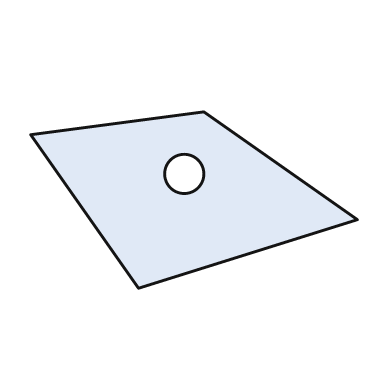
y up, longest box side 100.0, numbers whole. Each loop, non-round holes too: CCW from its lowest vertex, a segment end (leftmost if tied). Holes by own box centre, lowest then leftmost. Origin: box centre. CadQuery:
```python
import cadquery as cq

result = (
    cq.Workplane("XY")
    .moveTo(-17.0, -27.0)
    .lineTo(50.0, -6.0)
    .lineTo(3.0, 27.0)
    .lineTo(-50.0, 20.0)
    .close()
    .moveTo(-3.0, 8.0)
    .circle(6.0)
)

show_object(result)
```